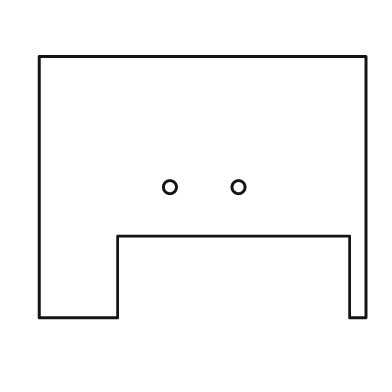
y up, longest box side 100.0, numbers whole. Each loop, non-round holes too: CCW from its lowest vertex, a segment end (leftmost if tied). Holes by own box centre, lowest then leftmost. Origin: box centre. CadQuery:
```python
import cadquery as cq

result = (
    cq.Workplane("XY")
    .moveTo(-50.0, -40.0)
    .lineTo(-26.0, -40.0)
    .lineTo(-26.0, -15.0)
    .lineTo(45.0, -15.0)
    .lineTo(45.0, -40.0)
    .lineTo(50.0, -40.0)
    .lineTo(50.0, 40.0)
    .lineTo(-50.0, 40.0)
    .close()
    .moveTo(-10.0, 0.0)
    .circle(2.0)
    .moveTo(11.0, 0.0)
    .circle(2.0)
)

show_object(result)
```